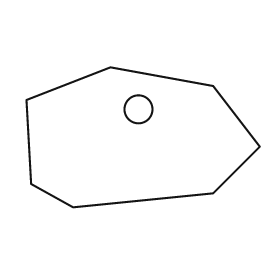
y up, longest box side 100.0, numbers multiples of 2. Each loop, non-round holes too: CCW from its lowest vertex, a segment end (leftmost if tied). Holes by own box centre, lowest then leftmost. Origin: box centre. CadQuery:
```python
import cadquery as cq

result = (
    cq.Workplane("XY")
    .moveTo(-30.0, -30.0)
    .lineTo(30.0, -24.0)
    .lineTo(50.0, -4.0)
    .lineTo(30.0, 22.0)
    .lineTo(-14.0, 30.0)
    .lineTo(-50.0, 16.0)
    .lineTo(-48.0, -20.0)
    .close()
    .moveTo(-2.0, 12.0)
    .circle(6.0)
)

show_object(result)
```